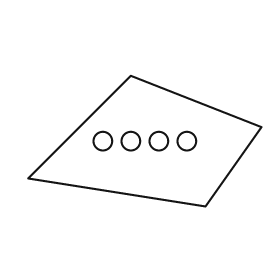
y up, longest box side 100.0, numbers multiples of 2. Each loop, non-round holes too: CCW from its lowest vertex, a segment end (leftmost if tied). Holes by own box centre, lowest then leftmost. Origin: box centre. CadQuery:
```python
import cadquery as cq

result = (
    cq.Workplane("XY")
    .moveTo(26.0, -28.0)
    .lineTo(50.0, 6.0)
    .lineTo(-6.0, 28.0)
    .lineTo(-50.0, -16.0)
    .close()
    .moveTo(-18.0, 0.0)
    .circle(4.0)
    .moveTo(-6.0, 0.0)
    .circle(4.0)
    .moveTo(6.0, 0.0)
    .circle(4.0)
    .moveTo(18.0, 0.0)
    .circle(4.0)
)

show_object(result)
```